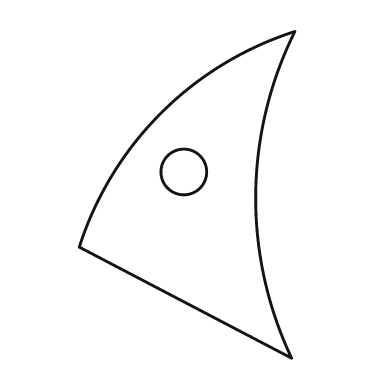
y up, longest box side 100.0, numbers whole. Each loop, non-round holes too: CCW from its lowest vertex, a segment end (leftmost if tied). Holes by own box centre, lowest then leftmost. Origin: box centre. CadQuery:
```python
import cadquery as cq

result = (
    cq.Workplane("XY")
    .moveTo(32.0, -50.0)
    .threePointArc((21.0, 0.0), (33.0, 50.0))
    .threePointArc((-8.0, 25.0), (-33.0, -16.0))
    .close()
    .moveTo(-1.0, 7.0)
    .circle(7.0)
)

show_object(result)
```